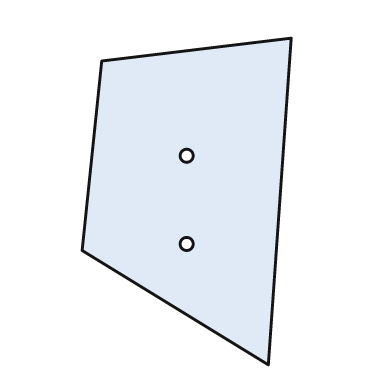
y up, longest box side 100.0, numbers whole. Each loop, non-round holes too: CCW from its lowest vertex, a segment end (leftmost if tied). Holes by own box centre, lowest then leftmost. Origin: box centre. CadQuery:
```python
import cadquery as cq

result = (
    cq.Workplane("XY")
    .moveTo(25.0, -50.0)
    .lineTo(32.0, 50.0)
    .lineTo(-26.0, 43.0)
    .lineTo(-32.0, -15.0)
    .close()
    .moveTo(0.0, -13.0)
    .circle(2.0)
    .moveTo(0.0, 14.0)
    .circle(2.0)
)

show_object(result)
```